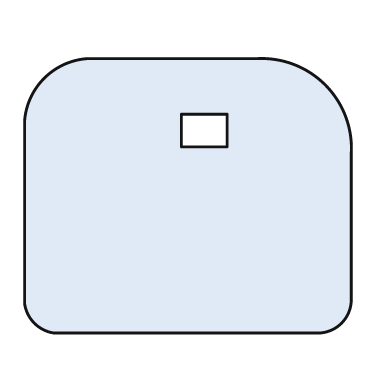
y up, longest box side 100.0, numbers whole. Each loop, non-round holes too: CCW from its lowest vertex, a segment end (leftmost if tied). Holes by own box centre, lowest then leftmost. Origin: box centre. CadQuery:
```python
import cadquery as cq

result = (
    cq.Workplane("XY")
    .moveTo(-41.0, -42.0)
    .lineTo(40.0, -42.0)
    .threePointArc((47.0, -39.0), (50.0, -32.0))
    .lineTo(50.0, 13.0)
    .threePointArc((42.0, 34.0), (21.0, 42.0))
    .lineTo(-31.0, 42.0)
    .threePointArc((-44.0, 36.0), (-50.0, 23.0))
    .lineTo(-50.0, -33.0)
    .threePointArc((-47.0, -39.0), (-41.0, -42.0))
    .close()
    .moveTo(-2.0, 15.0)
    .lineTo(12.0, 15.0)
    .lineTo(12.0, 25.0)
    .lineTo(-2.0, 25.0)
    .close()
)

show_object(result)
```